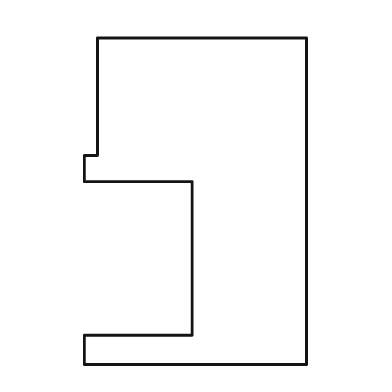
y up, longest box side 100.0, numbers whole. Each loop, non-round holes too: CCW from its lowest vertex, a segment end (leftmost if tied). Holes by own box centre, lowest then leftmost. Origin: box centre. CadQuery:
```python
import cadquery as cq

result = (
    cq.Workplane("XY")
    .moveTo(-34.0, -50.0)
    .lineTo(34.0, -50.0)
    .lineTo(34.0, 50.0)
    .lineTo(-30.0, 50.0)
    .lineTo(-30.0, 14.0)
    .lineTo(-34.0, 14.0)
    .lineTo(-34.0, 6.0)
    .lineTo(-1.0, 6.0)
    .lineTo(-1.0, -41.0)
    .lineTo(-34.0, -41.0)
    .close()
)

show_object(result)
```